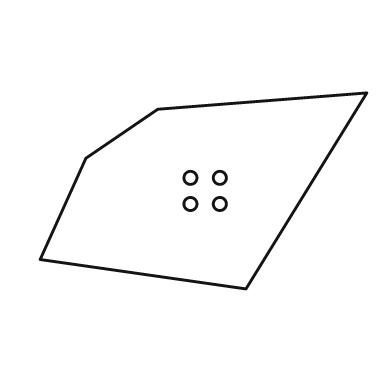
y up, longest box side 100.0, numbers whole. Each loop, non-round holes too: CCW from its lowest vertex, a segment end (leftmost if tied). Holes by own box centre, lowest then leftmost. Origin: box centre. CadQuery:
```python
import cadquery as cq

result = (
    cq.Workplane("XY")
    .moveTo(13.0, -30.0)
    .lineTo(50.0, 30.0)
    .lineTo(-14.0, 25.0)
    .lineTo(-36.0, 10.0)
    .lineTo(-50.0, -21.0)
    .close()
    .moveTo(-4.0, -4.0)
    .circle(2.0)
    .moveTo(5.0, -4.0)
    .circle(2.0)
    .moveTo(-4.0, 4.0)
    .circle(2.0)
    .moveTo(5.0, 4.0)
    .circle(2.0)
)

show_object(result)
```